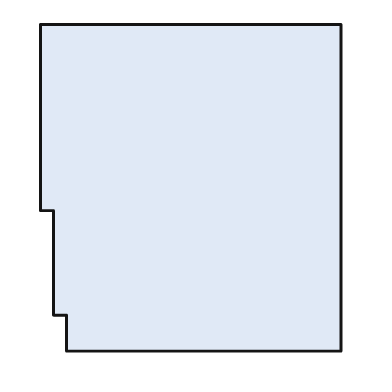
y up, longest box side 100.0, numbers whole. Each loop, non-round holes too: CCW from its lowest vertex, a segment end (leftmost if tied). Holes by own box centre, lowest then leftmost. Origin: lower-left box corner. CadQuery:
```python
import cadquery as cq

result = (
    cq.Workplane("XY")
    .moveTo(8.0, 0.0)
    .lineTo(92.0, 0.0)
    .lineTo(92.0, 100.0)
    .lineTo(0.0, 100.0)
    .lineTo(0.0, 43.0)
    .lineTo(4.0, 43.0)
    .lineTo(4.0, 11.0)
    .lineTo(8.0, 11.0)
    .close()
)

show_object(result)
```